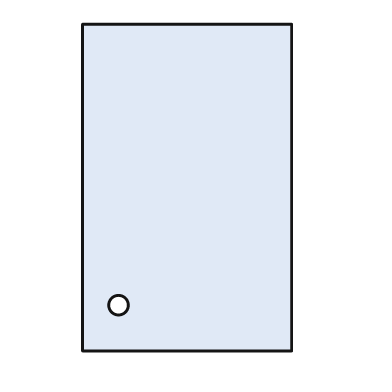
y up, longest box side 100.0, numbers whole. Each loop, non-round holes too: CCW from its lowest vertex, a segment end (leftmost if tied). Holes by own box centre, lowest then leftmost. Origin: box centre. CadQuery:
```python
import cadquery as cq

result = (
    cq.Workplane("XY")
    .moveTo(-32.0, -50.0)
    .lineTo(32.0, -50.0)
    .lineTo(32.0, 50.0)
    .lineTo(-32.0, 50.0)
    .close()
    .moveTo(-21.0, -36.0)
    .circle(3.0)
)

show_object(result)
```